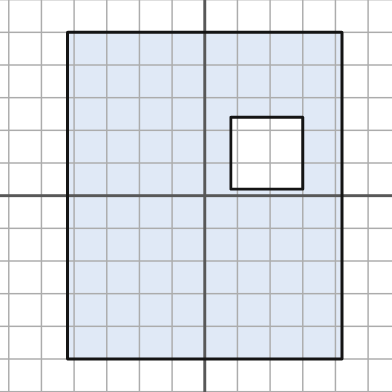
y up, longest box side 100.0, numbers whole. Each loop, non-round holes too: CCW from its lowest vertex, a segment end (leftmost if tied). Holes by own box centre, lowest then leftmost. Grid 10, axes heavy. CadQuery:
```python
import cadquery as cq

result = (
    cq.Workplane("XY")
    .moveTo(-42.0, -50.0)
    .lineTo(42.0, -50.0)
    .lineTo(42.0, 50.0)
    .lineTo(-42.0, 50.0)
    .close()
    .moveTo(8.0, 2.0)
    .lineTo(30.0, 2.0)
    .lineTo(30.0, 24.0)
    .lineTo(8.0, 24.0)
    .close()
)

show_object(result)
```